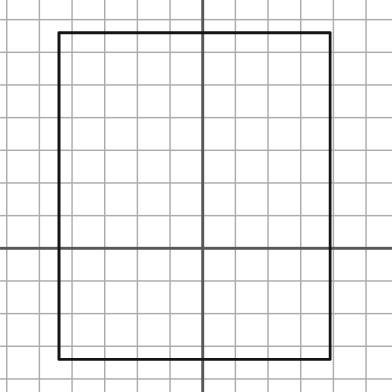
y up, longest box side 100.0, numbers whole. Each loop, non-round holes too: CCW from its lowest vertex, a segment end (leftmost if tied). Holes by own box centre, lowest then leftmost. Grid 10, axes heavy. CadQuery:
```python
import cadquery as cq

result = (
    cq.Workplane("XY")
    .moveTo(-44.0, -34.0)
    .lineTo(39.0, -34.0)
    .lineTo(39.0, 66.0)
    .lineTo(-44.0, 66.0)
    .close()
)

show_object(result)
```